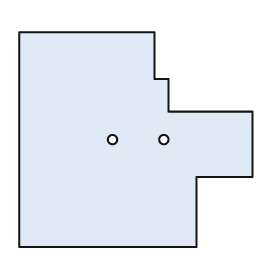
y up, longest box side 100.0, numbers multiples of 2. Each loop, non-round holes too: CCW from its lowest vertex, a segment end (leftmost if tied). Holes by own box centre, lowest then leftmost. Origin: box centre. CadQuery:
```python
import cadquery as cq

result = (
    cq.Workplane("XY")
    .moveTo(-50.0, -46.0)
    .lineTo(26.0, -46.0)
    .lineTo(26.0, -16.0)
    .lineTo(50.0, -16.0)
    .lineTo(50.0, 12.0)
    .lineTo(14.0, 12.0)
    .lineTo(14.0, 26.0)
    .lineTo(8.0, 26.0)
    .lineTo(8.0, 46.0)
    .lineTo(-50.0, 46.0)
    .close()
    .moveTo(-10.0, 0.0)
    .circle(2.0)
    .moveTo(12.0, 0.0)
    .circle(2.0)
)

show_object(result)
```